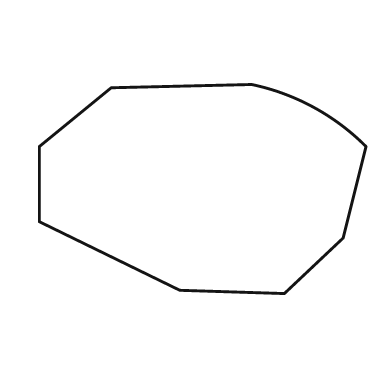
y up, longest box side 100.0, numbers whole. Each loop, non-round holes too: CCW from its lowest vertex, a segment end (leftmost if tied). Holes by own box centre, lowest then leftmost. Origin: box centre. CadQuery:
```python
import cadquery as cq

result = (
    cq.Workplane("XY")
    .moveTo(25.0, -32.0)
    .lineTo(43.0, -15.0)
    .lineTo(50.0, 13.0)
    .threePointArc((34.0, 25.0), (15.0, 32.0))
    .lineTo(-28.0, 31.0)
    .lineTo(-50.0, 13.0)
    .lineTo(-50.0, -10.0)
    .lineTo(-7.0, -31.0)
    .close()
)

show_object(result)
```